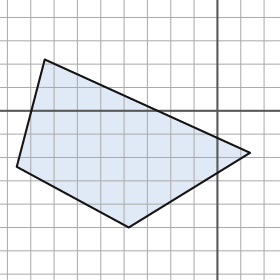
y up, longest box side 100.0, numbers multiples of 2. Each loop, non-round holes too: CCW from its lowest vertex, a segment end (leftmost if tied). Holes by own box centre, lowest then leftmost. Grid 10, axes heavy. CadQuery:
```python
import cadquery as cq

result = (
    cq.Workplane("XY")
    .moveTo(-38.0, -50.0)
    .lineTo(14.0, -18.0)
    .lineTo(-74.0, 22.0)
    .lineTo(-86.0, -24.0)
    .close()
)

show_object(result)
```